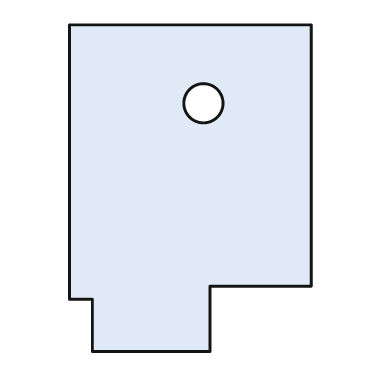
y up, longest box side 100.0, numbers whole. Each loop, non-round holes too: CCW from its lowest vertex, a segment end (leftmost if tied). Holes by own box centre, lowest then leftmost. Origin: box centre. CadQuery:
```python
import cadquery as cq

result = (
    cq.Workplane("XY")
    .moveTo(-30.0, -50.0)
    .lineTo(6.0, -50.0)
    .lineTo(6.0, -30.0)
    .lineTo(37.0, -30.0)
    .lineTo(37.0, 50.0)
    .lineTo(-37.0, 50.0)
    .lineTo(-37.0, -34.0)
    .lineTo(-30.0, -34.0)
    .close()
    .moveTo(4.0, 26.0)
    .circle(6.0)
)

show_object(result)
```